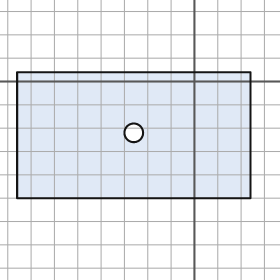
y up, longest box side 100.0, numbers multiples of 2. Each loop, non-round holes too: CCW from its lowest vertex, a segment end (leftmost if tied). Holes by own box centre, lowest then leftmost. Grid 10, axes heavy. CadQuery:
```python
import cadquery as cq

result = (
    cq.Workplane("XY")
    .moveTo(-76.0, -50.0)
    .lineTo(24.0, -50.0)
    .lineTo(24.0, 4.0)
    .lineTo(-76.0, 4.0)
    .close()
    .moveTo(-26.0, -22.0)
    .circle(4.0)
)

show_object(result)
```